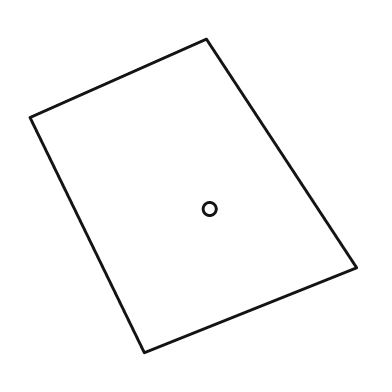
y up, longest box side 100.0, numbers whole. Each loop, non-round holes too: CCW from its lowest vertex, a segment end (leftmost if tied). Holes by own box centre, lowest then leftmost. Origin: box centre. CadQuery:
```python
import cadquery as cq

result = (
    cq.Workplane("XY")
    .moveTo(-15.0, -48.0)
    .lineTo(50.0, -22.0)
    .lineTo(4.0, 48.0)
    .lineTo(-50.0, 24.0)
    .close()
    .moveTo(5.0, -4.0)
    .circle(2.0)
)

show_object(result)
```